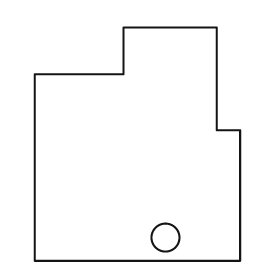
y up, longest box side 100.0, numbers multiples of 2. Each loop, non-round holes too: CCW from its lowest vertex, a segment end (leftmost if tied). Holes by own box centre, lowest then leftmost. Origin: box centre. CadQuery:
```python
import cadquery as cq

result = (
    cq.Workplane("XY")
    .moveTo(-44.0, -50.0)
    .lineTo(44.0, -50.0)
    .lineTo(44.0, 6.0)
    .lineTo(34.0, 6.0)
    .lineTo(34.0, 50.0)
    .lineTo(-6.0, 50.0)
    .lineTo(-6.0, 30.0)
    .lineTo(-44.0, 30.0)
    .close()
    .moveTo(12.0, -40.0)
    .circle(6.0)
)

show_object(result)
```